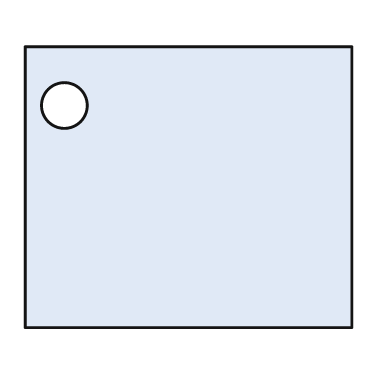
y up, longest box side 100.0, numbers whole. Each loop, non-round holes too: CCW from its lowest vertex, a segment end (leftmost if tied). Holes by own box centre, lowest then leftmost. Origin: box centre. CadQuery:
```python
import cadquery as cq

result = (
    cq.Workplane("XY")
    .moveTo(-50.0, -43.0)
    .lineTo(50.0, -43.0)
    .lineTo(50.0, 43.0)
    .lineTo(-50.0, 43.0)
    .close()
    .moveTo(-38.0, 25.0)
    .circle(7.0)
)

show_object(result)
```